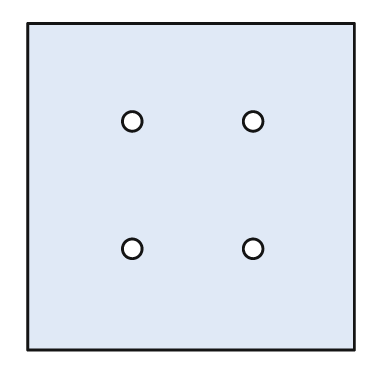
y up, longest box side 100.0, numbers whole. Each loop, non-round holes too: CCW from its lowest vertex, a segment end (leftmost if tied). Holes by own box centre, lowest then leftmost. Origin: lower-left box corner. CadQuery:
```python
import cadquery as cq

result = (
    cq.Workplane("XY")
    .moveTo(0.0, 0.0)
    .lineTo(100.0, 0.0)
    .lineTo(100.0, 100.0)
    .lineTo(0.0, 100.0)
    .close()
    .moveTo(32.0, 31.0)
    .circle(3.0)
    .moveTo(69.0, 31.0)
    .circle(3.0)
    .moveTo(32.0, 70.0)
    .circle(3.0)
    .moveTo(69.0, 70.0)
    .circle(3.0)
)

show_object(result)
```